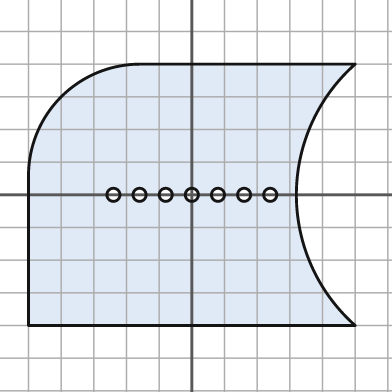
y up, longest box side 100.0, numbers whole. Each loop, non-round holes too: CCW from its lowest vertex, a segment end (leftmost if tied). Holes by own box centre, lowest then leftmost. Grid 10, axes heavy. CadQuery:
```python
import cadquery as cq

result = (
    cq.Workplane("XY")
    .moveTo(-50.0, -40.0)
    .lineTo(50.0, -40.0)
    .threePointArc((32.0, 0.0), (50.0, 40.0))
    .lineTo(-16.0, 40.0)
    .threePointArc((-40.0, 30.0), (-50.0, 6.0))
    .close()
    .moveTo(-24.0, 0.0)
    .circle(2.0)
    .moveTo(-16.0, 0.0)
    .circle(2.0)
    .moveTo(-8.0, 0.0)
    .circle(2.0)
    .moveTo(0.0, 0.0)
    .circle(2.0)
    .moveTo(8.0, 0.0)
    .circle(2.0)
    .moveTo(16.0, 0.0)
    .circle(2.0)
    .moveTo(24.0, 0.0)
    .circle(2.0)
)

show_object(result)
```